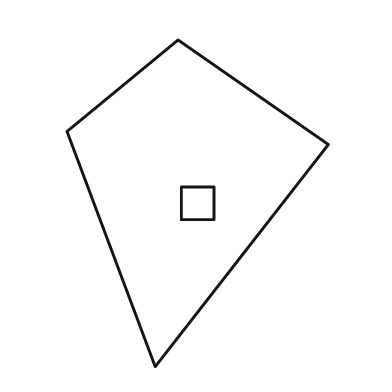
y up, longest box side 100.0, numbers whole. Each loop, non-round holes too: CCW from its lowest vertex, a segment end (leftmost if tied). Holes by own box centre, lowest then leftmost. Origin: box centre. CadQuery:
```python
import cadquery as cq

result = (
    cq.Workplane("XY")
    .moveTo(-13.0, -50.0)
    .lineTo(40.0, 18.0)
    .lineTo(-6.0, 50.0)
    .lineTo(-40.0, 22.0)
    .close()
    .moveTo(-5.0, -5.0)
    .lineTo(5.0, -5.0)
    .lineTo(5.0, 5.0)
    .lineTo(-5.0, 5.0)
    .close()
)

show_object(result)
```